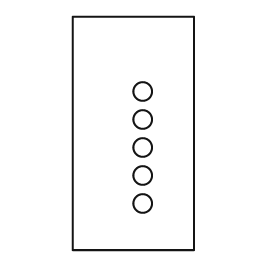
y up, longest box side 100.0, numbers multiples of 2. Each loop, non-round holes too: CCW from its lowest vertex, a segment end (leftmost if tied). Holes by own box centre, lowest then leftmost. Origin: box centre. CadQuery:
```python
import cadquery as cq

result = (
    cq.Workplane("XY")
    .moveTo(-26.0, -50.0)
    .lineTo(26.0, -50.0)
    .lineTo(26.0, 50.0)
    .lineTo(-26.0, 50.0)
    .close()
    .moveTo(4.0, -30.0)
    .circle(4.0)
    .moveTo(4.0, -18.0)
    .circle(4.0)
    .moveTo(4.0, -6.0)
    .circle(4.0)
    .moveTo(4.0, 6.0)
    .circle(4.0)
    .moveTo(4.0, 18.0)
    .circle(4.0)
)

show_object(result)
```